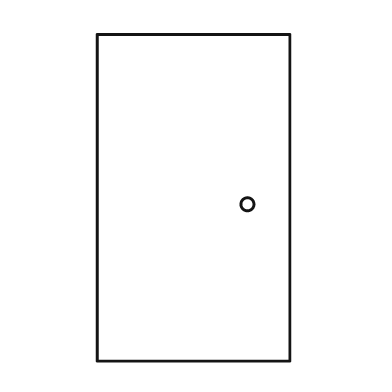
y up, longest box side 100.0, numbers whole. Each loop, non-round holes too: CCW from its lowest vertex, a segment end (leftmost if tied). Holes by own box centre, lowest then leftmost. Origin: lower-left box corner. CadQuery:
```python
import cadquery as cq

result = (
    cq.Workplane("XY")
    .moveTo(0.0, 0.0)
    .lineTo(59.0, 0.0)
    .lineTo(59.0, 100.0)
    .lineTo(0.0, 100.0)
    .close()
    .moveTo(46.0, 48.0)
    .circle(2.0)
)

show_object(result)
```